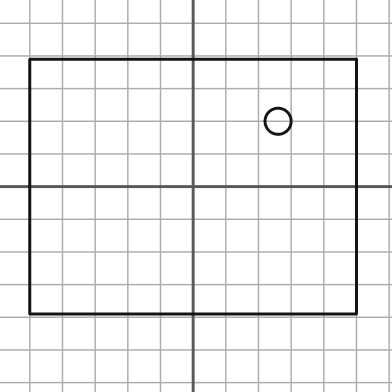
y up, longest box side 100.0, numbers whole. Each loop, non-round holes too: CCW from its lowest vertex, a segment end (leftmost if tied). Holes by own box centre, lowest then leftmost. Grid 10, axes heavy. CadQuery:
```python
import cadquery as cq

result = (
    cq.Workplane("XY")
    .moveTo(-50.0, -39.0)
    .lineTo(50.0, -39.0)
    .lineTo(50.0, 39.0)
    .lineTo(-50.0, 39.0)
    .close()
    .moveTo(26.0, 20.0)
    .circle(4.0)
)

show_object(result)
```